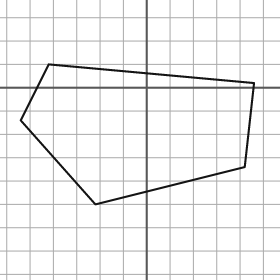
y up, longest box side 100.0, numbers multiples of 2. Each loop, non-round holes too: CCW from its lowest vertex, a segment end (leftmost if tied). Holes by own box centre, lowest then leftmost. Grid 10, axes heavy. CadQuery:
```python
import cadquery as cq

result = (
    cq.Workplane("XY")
    .moveTo(-22.0, -50.0)
    .lineTo(42.0, -34.0)
    .lineTo(46.0, 2.0)
    .lineTo(-42.0, 10.0)
    .lineTo(-54.0, -14.0)
    .close()
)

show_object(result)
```